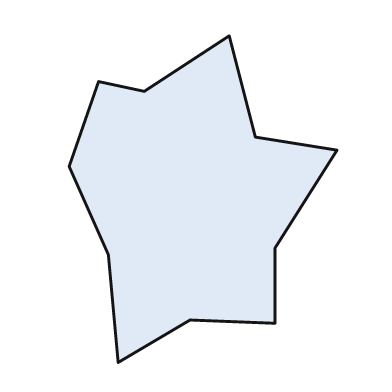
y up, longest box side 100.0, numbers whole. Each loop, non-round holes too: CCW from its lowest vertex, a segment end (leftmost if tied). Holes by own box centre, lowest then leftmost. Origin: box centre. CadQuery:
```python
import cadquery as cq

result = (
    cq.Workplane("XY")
    .moveTo(-26.0, -50.0)
    .lineTo(-4.0, -37.0)
    .lineTo(22.0, -38.0)
    .lineTo(22.0, -15.0)
    .lineTo(41.0, 15.0)
    .lineTo(16.0, 19.0)
    .lineTo(8.0, 50.0)
    .lineTo(-18.0, 33.0)
    .lineTo(-32.0, 36.0)
    .lineTo(-41.0, 10.0)
    .lineTo(-29.0, -17.0)
    .close()
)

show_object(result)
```